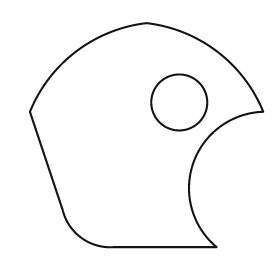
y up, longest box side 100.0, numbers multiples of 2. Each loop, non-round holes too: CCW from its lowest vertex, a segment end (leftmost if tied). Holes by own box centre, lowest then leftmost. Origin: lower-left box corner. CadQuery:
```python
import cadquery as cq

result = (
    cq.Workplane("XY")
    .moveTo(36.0, 0.0)
    .lineTo(80.0, 0.0)
    .threePointArc((70.0, 36.0), (100.0, 58.0))
    .threePointArc((80.0, 84.0), (50.0, 96.0))
    .threePointArc((20.0, 84.0), (0.0, 58.0))
    .lineTo(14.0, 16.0)
    .threePointArc((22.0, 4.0), (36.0, 0.0))
    .close()
    .moveTo(64.0, 62.0)
    .circle(12.0)
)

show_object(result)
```